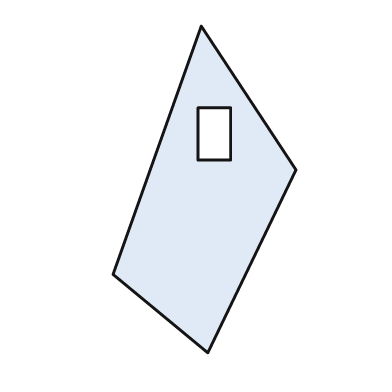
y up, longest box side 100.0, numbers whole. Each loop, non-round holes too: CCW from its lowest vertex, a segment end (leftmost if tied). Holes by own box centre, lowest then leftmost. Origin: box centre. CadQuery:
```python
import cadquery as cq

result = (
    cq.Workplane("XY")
    .moveTo(1.0, -50.0)
    .lineTo(28.0, 6.0)
    .lineTo(-1.0, 50.0)
    .lineTo(-28.0, -26.0)
    .close()
    .moveTo(-2.0, 9.0)
    .lineTo(8.0, 9.0)
    .lineTo(8.0, 25.0)
    .lineTo(-2.0, 25.0)
    .close()
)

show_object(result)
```